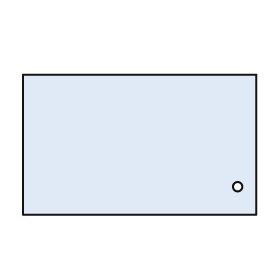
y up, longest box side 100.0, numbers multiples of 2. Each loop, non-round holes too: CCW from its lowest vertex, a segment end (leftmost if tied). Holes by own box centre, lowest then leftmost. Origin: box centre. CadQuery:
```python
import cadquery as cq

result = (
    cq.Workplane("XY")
    .moveTo(-50.0, -30.0)
    .lineTo(50.0, -30.0)
    .lineTo(50.0, 30.0)
    .lineTo(-50.0, 30.0)
    .close()
    .moveTo(42.0, -18.0)
    .circle(2.0)
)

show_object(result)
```